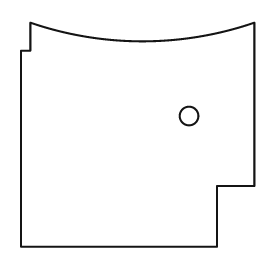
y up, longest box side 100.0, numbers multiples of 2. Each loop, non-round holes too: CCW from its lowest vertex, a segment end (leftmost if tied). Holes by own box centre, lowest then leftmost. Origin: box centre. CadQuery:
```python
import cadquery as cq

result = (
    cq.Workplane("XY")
    .moveTo(-50.0, -48.0)
    .lineTo(34.0, -48.0)
    .lineTo(34.0, -22.0)
    .lineTo(50.0, -22.0)
    .lineTo(50.0, 48.0)
    .threePointArc((2.0, 40.0), (-46.0, 48.0))
    .lineTo(-46.0, 36.0)
    .lineTo(-50.0, 36.0)
    .close()
    .moveTo(22.0, 8.0)
    .circle(4.0)
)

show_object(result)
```